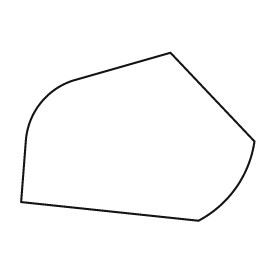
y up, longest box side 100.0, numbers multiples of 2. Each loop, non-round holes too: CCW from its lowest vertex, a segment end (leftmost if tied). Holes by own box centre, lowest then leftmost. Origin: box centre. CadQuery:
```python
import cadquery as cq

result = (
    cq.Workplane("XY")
    .moveTo(26.0, -36.0)
    .threePointArc((42.0, -22.0), (50.0, -2.0))
    .lineTo(14.0, 36.0)
    .lineTo(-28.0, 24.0)
    .threePointArc((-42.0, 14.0), (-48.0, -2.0))
    .lineTo(-50.0, -28.0)
    .close()
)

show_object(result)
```